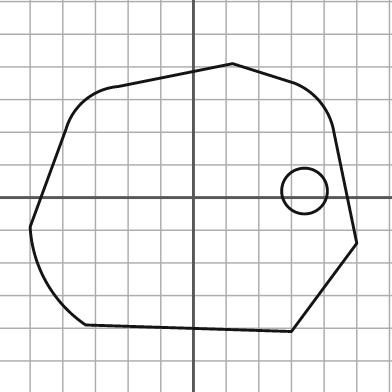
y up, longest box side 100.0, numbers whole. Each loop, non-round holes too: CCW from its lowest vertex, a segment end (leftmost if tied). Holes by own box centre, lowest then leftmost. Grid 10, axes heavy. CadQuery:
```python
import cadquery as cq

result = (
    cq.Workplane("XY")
    .moveTo(30.0, -41.0)
    .lineTo(50.0, -14.0)
    .lineTo(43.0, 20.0)
    .threePointArc((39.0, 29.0), (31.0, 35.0))
    .lineTo(12.0, 41.0)
    .lineTo(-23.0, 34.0)
    .threePointArc((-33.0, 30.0), (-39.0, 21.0))
    .lineTo(-50.0, -9.0)
    .threePointArc((-45.0, -26.0), (-33.0, -39.0))
    .close()
    .moveTo(34.0, 2.0)
    .circle(7.0)
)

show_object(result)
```